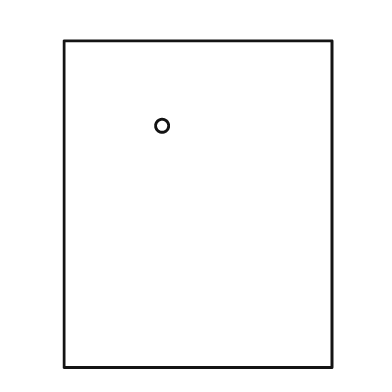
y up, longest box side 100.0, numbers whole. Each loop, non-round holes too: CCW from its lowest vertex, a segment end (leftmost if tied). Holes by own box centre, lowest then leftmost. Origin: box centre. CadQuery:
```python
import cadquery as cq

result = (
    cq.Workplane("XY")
    .moveTo(-41.0, -50.0)
    .lineTo(41.0, -50.0)
    .lineTo(41.0, 50.0)
    .lineTo(-41.0, 50.0)
    .close()
    .moveTo(-11.0, 24.0)
    .circle(2.0)
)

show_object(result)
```